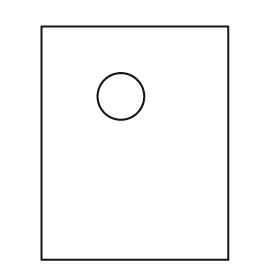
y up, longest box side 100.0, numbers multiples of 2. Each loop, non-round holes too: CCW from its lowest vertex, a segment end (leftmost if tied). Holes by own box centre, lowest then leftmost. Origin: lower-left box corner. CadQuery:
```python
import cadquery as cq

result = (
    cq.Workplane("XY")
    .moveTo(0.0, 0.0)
    .lineTo(80.0, 0.0)
    .lineTo(80.0, 100.0)
    .lineTo(0.0, 100.0)
    .close()
    .moveTo(34.0, 70.0)
    .circle(10.0)
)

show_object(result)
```